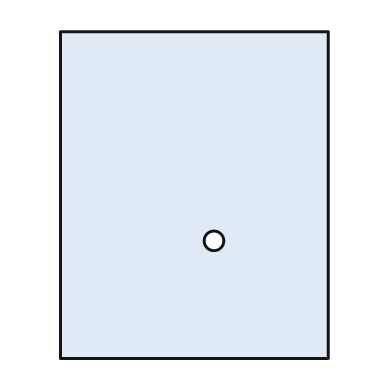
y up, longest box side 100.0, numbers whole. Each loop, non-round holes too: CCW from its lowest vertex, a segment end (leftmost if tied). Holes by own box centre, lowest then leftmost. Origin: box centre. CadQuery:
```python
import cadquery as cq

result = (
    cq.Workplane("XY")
    .moveTo(-41.0, -50.0)
    .lineTo(41.0, -50.0)
    .lineTo(41.0, 50.0)
    .lineTo(-41.0, 50.0)
    .close()
    .moveTo(6.0, -14.0)
    .circle(3.0)
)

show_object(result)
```